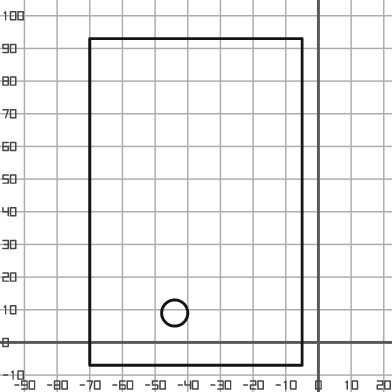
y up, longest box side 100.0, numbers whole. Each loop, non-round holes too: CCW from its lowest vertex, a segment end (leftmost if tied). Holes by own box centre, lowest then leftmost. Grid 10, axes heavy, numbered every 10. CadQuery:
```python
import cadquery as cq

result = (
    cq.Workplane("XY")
    .moveTo(-70.0, -7.0)
    .lineTo(-5.0, -7.0)
    .lineTo(-5.0, 93.0)
    .lineTo(-70.0, 93.0)
    .close()
    .moveTo(-44.0, 9.0)
    .circle(4.0)
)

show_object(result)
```